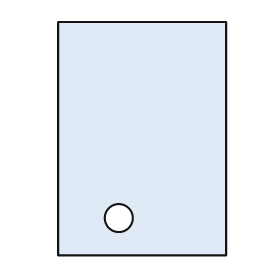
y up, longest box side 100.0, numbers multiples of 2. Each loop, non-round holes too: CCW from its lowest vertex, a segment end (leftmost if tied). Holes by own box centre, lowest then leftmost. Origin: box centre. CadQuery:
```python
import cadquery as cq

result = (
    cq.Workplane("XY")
    .moveTo(-36.0, -50.0)
    .lineTo(36.0, -50.0)
    .lineTo(36.0, 50.0)
    .lineTo(-36.0, 50.0)
    .close()
    .moveTo(-10.0, -34.0)
    .circle(6.0)
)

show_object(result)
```